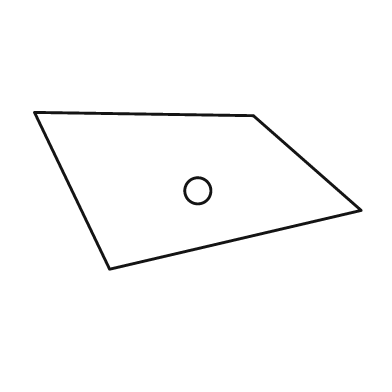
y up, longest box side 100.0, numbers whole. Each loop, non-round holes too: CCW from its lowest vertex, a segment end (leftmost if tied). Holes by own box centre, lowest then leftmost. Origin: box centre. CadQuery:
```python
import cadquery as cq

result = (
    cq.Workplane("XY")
    .moveTo(-27.0, -24.0)
    .lineTo(50.0, -6.0)
    .lineTo(17.0, 23.0)
    .lineTo(-50.0, 24.0)
    .close()
    .moveTo(0.0, 0.0)
    .circle(4.0)
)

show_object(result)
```